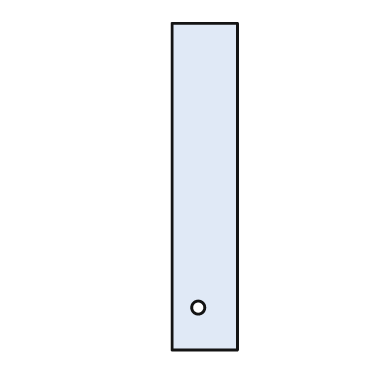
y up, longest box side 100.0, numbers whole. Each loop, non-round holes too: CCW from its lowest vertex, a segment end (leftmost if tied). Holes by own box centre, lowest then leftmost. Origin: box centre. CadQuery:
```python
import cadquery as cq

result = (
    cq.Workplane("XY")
    .moveTo(-10.0, -50.0)
    .lineTo(10.0, -50.0)
    .lineTo(10.0, 50.0)
    .lineTo(-10.0, 50.0)
    .close()
    .moveTo(-2.0, -37.0)
    .circle(2.0)
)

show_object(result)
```